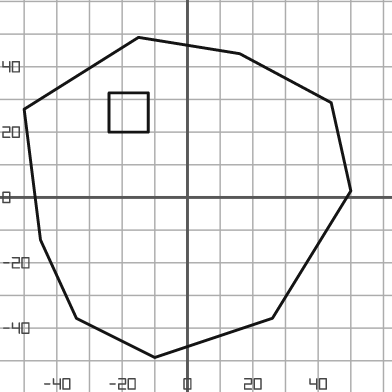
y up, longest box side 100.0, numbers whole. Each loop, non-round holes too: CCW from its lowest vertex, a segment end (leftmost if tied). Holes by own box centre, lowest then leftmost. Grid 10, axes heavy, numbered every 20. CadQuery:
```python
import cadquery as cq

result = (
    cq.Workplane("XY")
    .moveTo(-10.0, -49.0)
    .lineTo(26.0, -37.0)
    .lineTo(50.0, 2.0)
    .lineTo(44.0, 29.0)
    .lineTo(16.0, 44.0)
    .lineTo(-15.0, 49.0)
    .lineTo(-50.0, 27.0)
    .lineTo(-45.0, -13.0)
    .lineTo(-34.0, -37.0)
    .close()
    .moveTo(-24.0, 20.0)
    .lineTo(-12.0, 20.0)
    .lineTo(-12.0, 32.0)
    .lineTo(-24.0, 32.0)
    .close()
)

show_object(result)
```